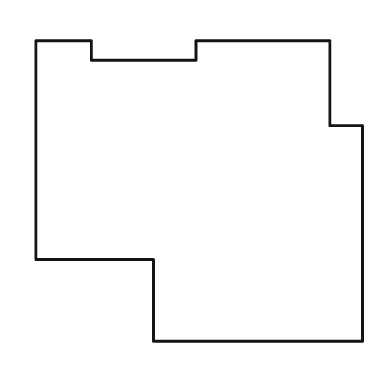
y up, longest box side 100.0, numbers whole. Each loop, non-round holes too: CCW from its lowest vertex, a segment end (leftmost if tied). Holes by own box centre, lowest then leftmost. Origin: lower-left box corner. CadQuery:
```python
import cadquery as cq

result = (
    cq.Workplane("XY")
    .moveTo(36.0, 0.0)
    .lineTo(100.0, 0.0)
    .lineTo(100.0, 66.0)
    .lineTo(90.0, 66.0)
    .lineTo(90.0, 92.0)
    .lineTo(49.0, 92.0)
    .lineTo(49.0, 86.0)
    .lineTo(17.0, 86.0)
    .lineTo(17.0, 92.0)
    .lineTo(0.0, 92.0)
    .lineTo(0.0, 25.0)
    .lineTo(36.0, 25.0)
    .close()
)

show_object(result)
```